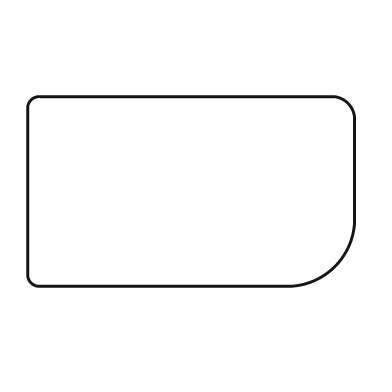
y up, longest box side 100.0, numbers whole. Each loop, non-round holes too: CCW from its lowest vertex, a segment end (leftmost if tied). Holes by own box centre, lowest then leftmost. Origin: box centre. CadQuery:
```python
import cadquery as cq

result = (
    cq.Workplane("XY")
    .moveTo(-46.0, -29.0)
    .lineTo(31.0, -29.0)
    .threePointArc((44.0, -23.0), (50.0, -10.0))
    .lineTo(50.0, 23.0)
    .threePointArc((48.0, 27.0), (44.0, 29.0))
    .lineTo(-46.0, 29.0)
    .threePointArc((-49.0, 28.0), (-50.0, 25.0))
    .lineTo(-50.0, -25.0)
    .threePointArc((-49.0, -28.0), (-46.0, -29.0))
    .close()
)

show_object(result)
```